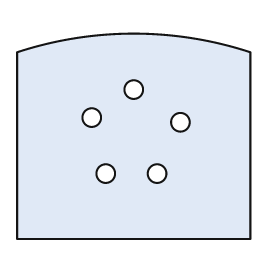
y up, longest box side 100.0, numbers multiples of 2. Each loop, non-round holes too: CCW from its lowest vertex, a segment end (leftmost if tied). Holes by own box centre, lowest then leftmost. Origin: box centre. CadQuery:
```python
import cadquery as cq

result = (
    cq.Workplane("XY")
    .moveTo(-50.0, -44.0)
    .lineTo(50.0, -44.0)
    .lineTo(50.0, 36.0)
    .threePointArc((0.0, 44.0), (-50.0, 36.0))
    .close()
    .moveTo(-12.0, -16.0)
    .circle(4.0)
    .moveTo(10.0, -16.0)
    .circle(4.0)
    .moveTo(20.0, 6.0)
    .circle(4.0)
    .moveTo(-18.0, 8.0)
    .circle(4.0)
    .moveTo(0.0, 20.0)
    .circle(4.0)
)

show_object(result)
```